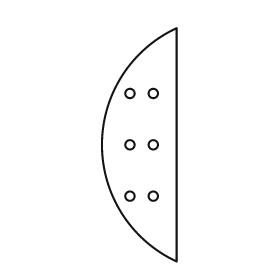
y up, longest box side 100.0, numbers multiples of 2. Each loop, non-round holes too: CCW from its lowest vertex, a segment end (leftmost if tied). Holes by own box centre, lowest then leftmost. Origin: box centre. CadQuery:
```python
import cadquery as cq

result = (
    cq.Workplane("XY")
    .moveTo(16.0, -50.0)
    .lineTo(16.0, 50.0)
    .threePointArc((-16.0, 0.0), (16.0, -50.0))
    .close()
    .moveTo(-4.0, -22.0)
    .circle(2.0)
    .moveTo(6.0, -22.0)
    .circle(2.0)
    .moveTo(-4.0, 0.0)
    .circle(2.0)
    .moveTo(6.0, 0.0)
    .circle(2.0)
    .moveTo(-4.0, 22.0)
    .circle(2.0)
    .moveTo(6.0, 22.0)
    .circle(2.0)
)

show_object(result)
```